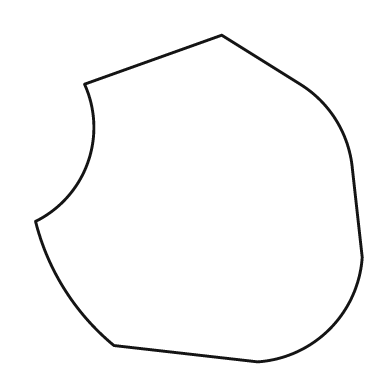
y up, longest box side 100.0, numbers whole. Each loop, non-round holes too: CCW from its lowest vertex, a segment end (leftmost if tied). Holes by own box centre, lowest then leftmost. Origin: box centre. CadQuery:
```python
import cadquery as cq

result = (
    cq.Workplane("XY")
    .moveTo(18.0, -50.0)
    .threePointArc((40.0, -40.0), (50.0, -18.0))
    .lineTo(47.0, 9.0)
    .threePointArc((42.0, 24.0), (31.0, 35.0))
    .lineTo(7.0, 50.0)
    .lineTo(-35.0, 35.0)
    .threePointArc((-34.0, 11.0), (-50.0, -7.0))
    .threePointArc((-41.0, -28.0), (-26.0, -45.0))
    .close()
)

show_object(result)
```